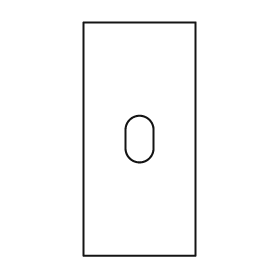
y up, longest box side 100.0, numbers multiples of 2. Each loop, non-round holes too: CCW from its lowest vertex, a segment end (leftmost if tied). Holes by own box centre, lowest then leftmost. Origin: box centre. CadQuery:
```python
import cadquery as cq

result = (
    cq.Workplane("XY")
    .moveTo(-24.0, -50.0)
    .lineTo(24.0, -50.0)
    .lineTo(24.0, 50.0)
    .lineTo(-24.0, 50.0)
    .close()
    .moveTo(-6.0, -4.0)
    .threePointArc((0.0, -10.0), (6.0, -4.0))
    .lineTo(6.0, 4.0)
    .threePointArc((0.0, 10.0), (-6.0, 4.0))
    .close()
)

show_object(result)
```